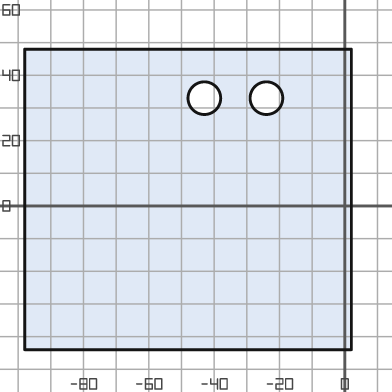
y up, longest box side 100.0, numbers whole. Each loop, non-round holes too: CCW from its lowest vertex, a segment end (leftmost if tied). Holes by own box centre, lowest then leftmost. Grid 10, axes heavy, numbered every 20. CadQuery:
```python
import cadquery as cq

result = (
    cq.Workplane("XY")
    .moveTo(-98.0, -44.0)
    .lineTo(2.0, -44.0)
    .lineTo(2.0, 48.0)
    .lineTo(-98.0, 48.0)
    .close()
    .moveTo(-43.0, 33.0)
    .circle(5.0)
    .moveTo(-24.0, 33.0)
    .circle(5.0)
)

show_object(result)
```